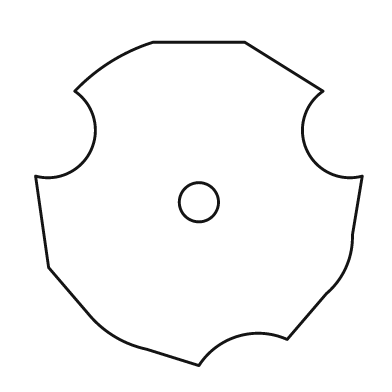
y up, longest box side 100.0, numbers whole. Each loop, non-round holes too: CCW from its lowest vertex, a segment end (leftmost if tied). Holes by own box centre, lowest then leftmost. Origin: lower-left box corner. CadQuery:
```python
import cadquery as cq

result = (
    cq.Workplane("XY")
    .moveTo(50.0, 0.0)
    .threePointArc((62.0, 9.0), (77.0, 8.0))
    .lineTo(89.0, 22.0)
    .threePointArc((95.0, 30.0), (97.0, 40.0))
    .lineTo(100.0, 58.0)
    .threePointArc((83.0, 66.0), (88.0, 84.0))
    .lineTo(64.0, 99.0)
    .lineTo(36.0, 99.0)
    .threePointArc((23.0, 93.0), (12.0, 84.0))
    .threePointArc((17.0, 66.0), (0.0, 58.0))
    .lineTo(4.0, 30.0)
    .lineTo(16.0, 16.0)
    .threePointArc((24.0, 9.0), (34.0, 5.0))
    .close()
    .moveTo(50.0, 50.0)
    .circle(6.0)
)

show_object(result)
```